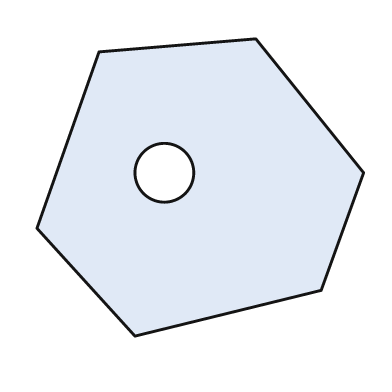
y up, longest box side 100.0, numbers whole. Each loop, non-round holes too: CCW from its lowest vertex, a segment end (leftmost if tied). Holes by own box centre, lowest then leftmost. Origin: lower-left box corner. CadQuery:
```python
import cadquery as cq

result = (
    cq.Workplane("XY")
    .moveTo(30.0, 0.0)
    .lineTo(87.0, 14.0)
    .lineTo(100.0, 50.0)
    .lineTo(67.0, 91.0)
    .lineTo(19.0, 87.0)
    .lineTo(0.0, 33.0)
    .close()
    .moveTo(39.0, 50.0)
    .circle(9.0)
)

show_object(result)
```